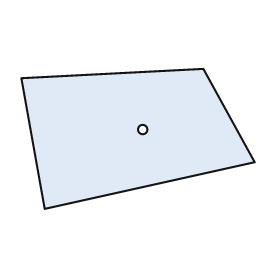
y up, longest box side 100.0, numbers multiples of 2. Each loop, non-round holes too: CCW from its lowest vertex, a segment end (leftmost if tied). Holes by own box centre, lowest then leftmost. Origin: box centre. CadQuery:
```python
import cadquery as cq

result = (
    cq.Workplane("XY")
    .moveTo(-40.0, -30.0)
    .lineTo(50.0, -10.0)
    .lineTo(28.0, 30.0)
    .lineTo(-50.0, 26.0)
    .close()
    .moveTo(2.0, 4.0)
    .circle(2.0)
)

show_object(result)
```